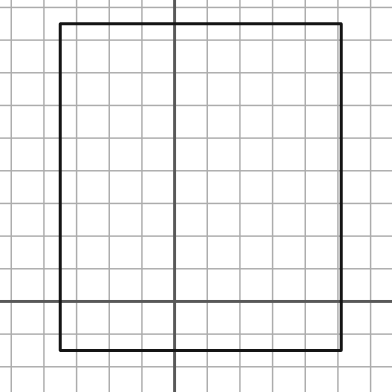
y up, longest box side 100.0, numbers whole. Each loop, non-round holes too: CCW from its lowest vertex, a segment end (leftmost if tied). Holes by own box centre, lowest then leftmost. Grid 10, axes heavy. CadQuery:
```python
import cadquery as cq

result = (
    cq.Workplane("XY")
    .moveTo(-35.0, -15.0)
    .lineTo(51.0, -15.0)
    .lineTo(51.0, 85.0)
    .lineTo(-35.0, 85.0)
    .close()
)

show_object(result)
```